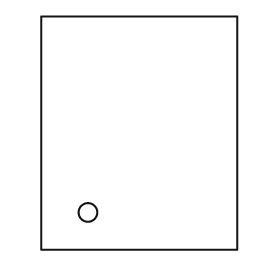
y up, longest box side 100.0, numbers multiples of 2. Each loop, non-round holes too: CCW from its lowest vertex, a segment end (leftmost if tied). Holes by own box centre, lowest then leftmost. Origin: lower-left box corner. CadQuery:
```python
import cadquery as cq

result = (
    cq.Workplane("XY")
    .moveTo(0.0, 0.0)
    .lineTo(84.0, 0.0)
    .lineTo(84.0, 100.0)
    .lineTo(0.0, 100.0)
    .close()
    .moveTo(20.0, 16.0)
    .circle(4.0)
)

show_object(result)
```